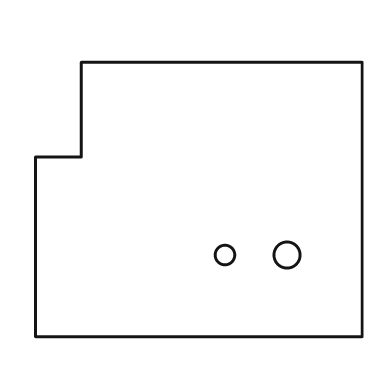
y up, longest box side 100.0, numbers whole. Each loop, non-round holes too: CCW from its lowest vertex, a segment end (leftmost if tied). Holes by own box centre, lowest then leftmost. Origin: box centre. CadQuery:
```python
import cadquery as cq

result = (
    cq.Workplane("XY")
    .moveTo(-50.0, -42.0)
    .lineTo(50.0, -42.0)
    .lineTo(50.0, 42.0)
    .lineTo(-36.0, 42.0)
    .lineTo(-36.0, 13.0)
    .lineTo(-50.0, 13.0)
    .close()
    .moveTo(8.0, -17.0)
    .circle(3.0)
    .moveTo(27.0, -17.0)
    .circle(4.0)
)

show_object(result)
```